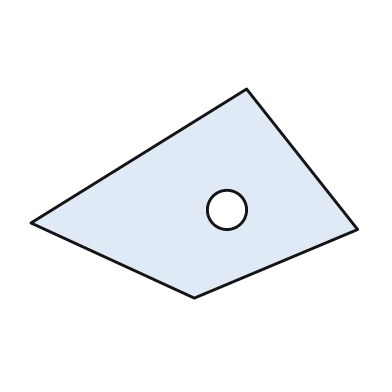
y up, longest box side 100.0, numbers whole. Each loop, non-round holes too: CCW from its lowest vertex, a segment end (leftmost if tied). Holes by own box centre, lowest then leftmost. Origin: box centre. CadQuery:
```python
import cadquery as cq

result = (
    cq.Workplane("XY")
    .moveTo(0.0, -32.0)
    .lineTo(50.0, -11.0)
    .lineTo(16.0, 32.0)
    .lineTo(-50.0, -9.0)
    .close()
    .moveTo(10.0, -5.0)
    .circle(6.0)
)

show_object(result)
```